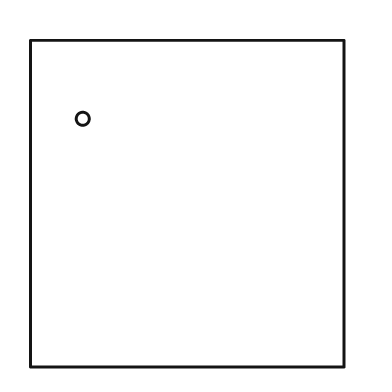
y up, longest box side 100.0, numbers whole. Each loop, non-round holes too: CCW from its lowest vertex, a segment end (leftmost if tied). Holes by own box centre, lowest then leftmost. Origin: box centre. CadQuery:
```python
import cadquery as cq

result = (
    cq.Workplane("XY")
    .moveTo(-48.0, -50.0)
    .lineTo(48.0, -50.0)
    .lineTo(48.0, 50.0)
    .lineTo(-48.0, 50.0)
    .close()
    .moveTo(-32.0, 26.0)
    .circle(2.0)
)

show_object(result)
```